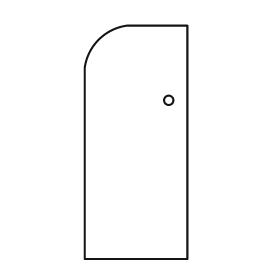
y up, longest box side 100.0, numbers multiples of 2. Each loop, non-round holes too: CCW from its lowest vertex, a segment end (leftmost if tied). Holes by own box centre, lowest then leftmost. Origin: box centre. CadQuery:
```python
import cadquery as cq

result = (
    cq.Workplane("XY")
    .moveTo(-22.0, -50.0)
    .lineTo(22.0, -50.0)
    .lineTo(22.0, 50.0)
    .lineTo(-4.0, 50.0)
    .threePointArc((-16.0, 44.0), (-22.0, 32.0))
    .close()
    .moveTo(14.0, 18.0)
    .circle(2.0)
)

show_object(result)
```